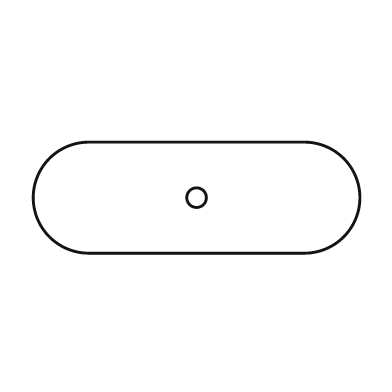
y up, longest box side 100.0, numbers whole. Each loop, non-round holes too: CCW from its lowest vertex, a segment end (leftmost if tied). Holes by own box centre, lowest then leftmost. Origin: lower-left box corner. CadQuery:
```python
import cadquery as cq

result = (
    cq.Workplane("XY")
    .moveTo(17.0, 0.0)
    .lineTo(83.0, 0.0)
    .threePointArc((100.0, 17.0), (83.0, 34.0))
    .lineTo(17.0, 34.0)
    .threePointArc((0.0, 17.0), (17.0, 0.0))
    .close()
    .moveTo(50.0, 17.0)
    .circle(3.0)
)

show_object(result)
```